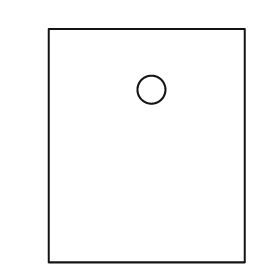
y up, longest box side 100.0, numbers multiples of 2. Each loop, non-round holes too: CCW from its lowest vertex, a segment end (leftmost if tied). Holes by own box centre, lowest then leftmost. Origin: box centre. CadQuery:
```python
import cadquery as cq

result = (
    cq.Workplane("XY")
    .moveTo(-42.0, -50.0)
    .lineTo(42.0, -50.0)
    .lineTo(42.0, 50.0)
    .lineTo(-42.0, 50.0)
    .close()
    .moveTo(2.0, 24.0)
    .circle(6.0)
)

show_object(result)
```